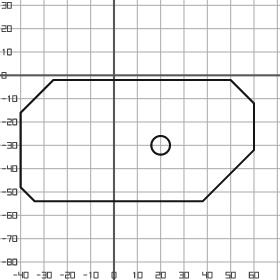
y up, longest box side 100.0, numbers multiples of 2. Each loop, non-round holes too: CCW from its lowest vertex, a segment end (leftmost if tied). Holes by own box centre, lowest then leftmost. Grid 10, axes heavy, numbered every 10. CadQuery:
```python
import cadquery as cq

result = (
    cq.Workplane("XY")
    .moveTo(-34.0, -54.0)
    .lineTo(38.0, -54.0)
    .lineTo(60.0, -32.0)
    .lineTo(60.0, -12.0)
    .lineTo(50.0, -2.0)
    .lineTo(-26.0, -2.0)
    .lineTo(-40.0, -16.0)
    .lineTo(-40.0, -48.0)
    .close()
    .moveTo(20.0, -30.0)
    .circle(4.0)
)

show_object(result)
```